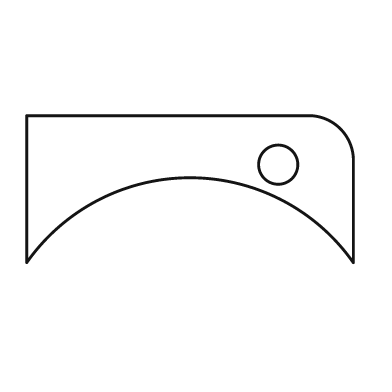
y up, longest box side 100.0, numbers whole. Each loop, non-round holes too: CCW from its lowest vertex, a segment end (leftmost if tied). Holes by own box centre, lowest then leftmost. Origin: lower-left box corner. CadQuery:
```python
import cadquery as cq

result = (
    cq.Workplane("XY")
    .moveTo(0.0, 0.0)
    .threePointArc((50.0, 26.0), (100.0, 0.0))
    .lineTo(100.0, 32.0)
    .threePointArc((96.0, 41.0), (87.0, 45.0))
    .lineTo(0.0, 45.0)
    .close()
    .moveTo(77.0, 30.0)
    .circle(6.0)
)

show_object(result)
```